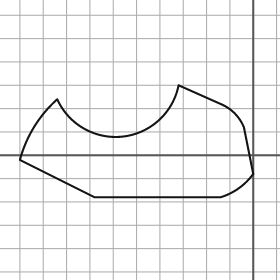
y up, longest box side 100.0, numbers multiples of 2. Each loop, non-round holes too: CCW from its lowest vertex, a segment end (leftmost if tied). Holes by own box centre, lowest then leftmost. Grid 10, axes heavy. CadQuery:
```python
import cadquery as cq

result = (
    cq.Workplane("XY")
    .moveTo(-68.0, -18.0)
    .lineTo(-14.0, -18.0)
    .threePointArc((-6.0, -14.0), (0.0, -8.0))
    .lineTo(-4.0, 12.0)
    .threePointArc((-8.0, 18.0), (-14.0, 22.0))
    .lineTo(-32.0, 30.0)
    .threePointArc((-56.0, 8.0), (-84.0, 24.0))
    .threePointArc((-94.0, 12.0), (-100.0, -2.0))
    .close()
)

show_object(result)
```